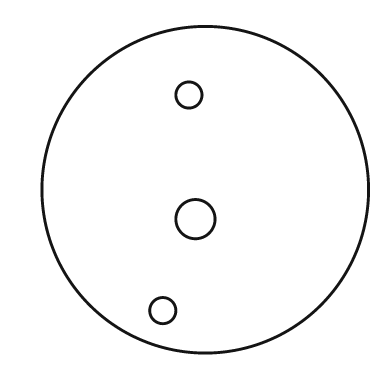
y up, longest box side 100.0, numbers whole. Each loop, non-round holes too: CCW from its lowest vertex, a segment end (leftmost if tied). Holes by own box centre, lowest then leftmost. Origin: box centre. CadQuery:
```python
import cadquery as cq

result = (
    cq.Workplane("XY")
    .moveTo(0.0, 0.0)
    .circle(50.0)
    .moveTo(-13.0, -37.0)
    .circle(4.0)
    .moveTo(-3.0, -9.0)
    .circle(6.0)
    .moveTo(-5.0, 29.0)
    .circle(4.0)
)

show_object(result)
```